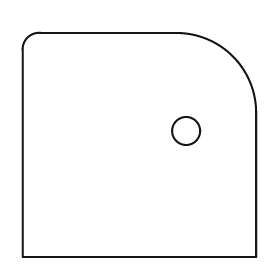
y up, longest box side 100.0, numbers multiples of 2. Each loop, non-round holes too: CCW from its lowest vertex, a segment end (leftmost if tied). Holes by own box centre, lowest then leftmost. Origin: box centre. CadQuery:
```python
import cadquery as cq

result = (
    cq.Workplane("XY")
    .moveTo(-50.0, -48.0)
    .lineTo(50.0, -48.0)
    .lineTo(50.0, 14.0)
    .threePointArc((40.0, 38.0), (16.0, 48.0))
    .lineTo(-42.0, 48.0)
    .threePointArc((-48.0, 46.0), (-50.0, 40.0))
    .close()
    .moveTo(20.0, 6.0)
    .circle(6.0)
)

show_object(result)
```